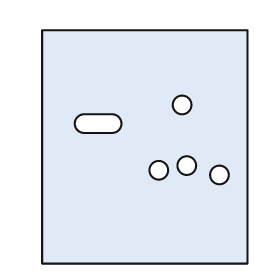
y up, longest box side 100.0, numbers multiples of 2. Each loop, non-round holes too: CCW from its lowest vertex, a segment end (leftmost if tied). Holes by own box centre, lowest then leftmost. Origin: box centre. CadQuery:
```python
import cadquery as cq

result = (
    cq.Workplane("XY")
    .moveTo(-44.0, -50.0)
    .lineTo(44.0, -50.0)
    .lineTo(44.0, 50.0)
    .lineTo(-44.0, 50.0)
    .close()
    .moveTo(32.0, -12.0)
    .circle(4.0)
    .moveTo(6.0, -10.0)
    .circle(4.0)
    .moveTo(18.0, -8.0)
    .circle(4.0)
    .moveTo(-26.0, 6.0)
    .lineTo(-14.0, 6.0)
    .threePointArc((-10.0, 10.0), (-14.0, 14.0))
    .lineTo(-26.0, 14.0)
    .threePointArc((-30.0, 10.0), (-26.0, 6.0))
    .close()
    .moveTo(16.0, 18.0)
    .circle(4.0)
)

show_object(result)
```